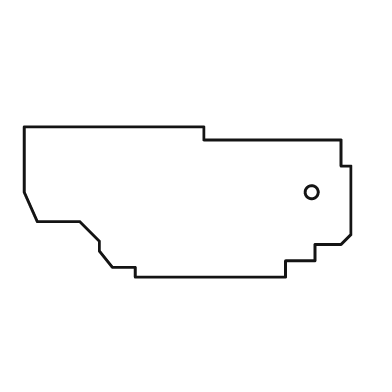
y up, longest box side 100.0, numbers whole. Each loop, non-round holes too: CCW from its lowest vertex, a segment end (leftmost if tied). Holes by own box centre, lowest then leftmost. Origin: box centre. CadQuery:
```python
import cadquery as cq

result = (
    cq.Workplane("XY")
    .moveTo(-16.0, -23.0)
    .lineTo(30.0, -23.0)
    .lineTo(30.0, -18.0)
    .lineTo(39.0, -18.0)
    .lineTo(39.0, -13.0)
    .lineTo(47.0, -13.0)
    .lineTo(50.0, -10.0)
    .lineTo(50.0, 11.0)
    .lineTo(47.0, 11.0)
    .lineTo(47.0, 19.0)
    .lineTo(5.0, 19.0)
    .lineTo(5.0, 23.0)
    .lineTo(-50.0, 23.0)
    .lineTo(-50.0, 3.0)
    .lineTo(-46.0, -6.0)
    .lineTo(-33.0, -6.0)
    .lineTo(-27.0, -12.0)
    .lineTo(-27.0, -15.0)
    .lineTo(-23.0, -20.0)
    .lineTo(-16.0, -20.0)
    .close()
    .moveTo(38.0, 3.0)
    .circle(2.0)
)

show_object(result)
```